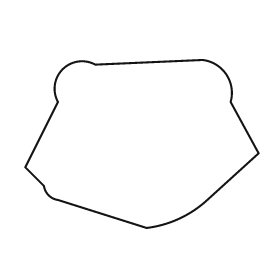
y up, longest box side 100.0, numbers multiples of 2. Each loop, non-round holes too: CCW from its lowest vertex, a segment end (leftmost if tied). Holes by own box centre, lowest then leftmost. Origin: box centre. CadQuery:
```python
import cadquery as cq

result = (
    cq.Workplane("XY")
    .moveTo(2.0, -36.0)
    .threePointArc((16.0, -32.0), (28.0, -24.0))
    .lineTo(50.0, -4.0)
    .lineTo(38.0, 18.0)
    .threePointArc((36.0, 30.0), (26.0, 36.0))
    .lineTo(-20.0, 34.0)
    .threePointArc((-34.0, 32.0), (-36.0, 18.0))
    .lineTo(-50.0, -10.0)
    .lineTo(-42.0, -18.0)
    .threePointArc((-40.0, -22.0), (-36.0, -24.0))
    .close()
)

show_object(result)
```